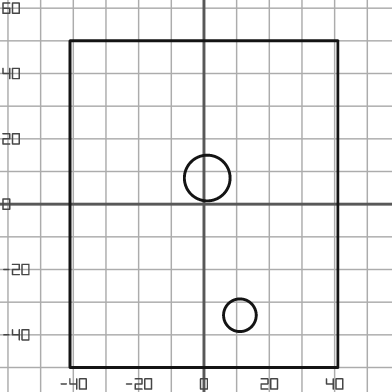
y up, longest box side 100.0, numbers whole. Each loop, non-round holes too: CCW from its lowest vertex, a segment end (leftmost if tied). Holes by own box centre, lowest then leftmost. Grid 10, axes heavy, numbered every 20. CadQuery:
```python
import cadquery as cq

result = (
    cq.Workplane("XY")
    .moveTo(-41.0, -50.0)
    .lineTo(41.0, -50.0)
    .lineTo(41.0, 50.0)
    .lineTo(-41.0, 50.0)
    .close()
    .moveTo(11.0, -34.0)
    .circle(5.0)
    .moveTo(1.0, 8.0)
    .circle(7.0)
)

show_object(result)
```